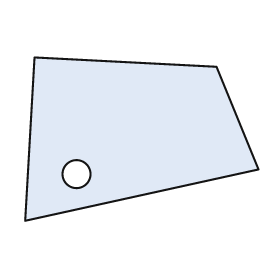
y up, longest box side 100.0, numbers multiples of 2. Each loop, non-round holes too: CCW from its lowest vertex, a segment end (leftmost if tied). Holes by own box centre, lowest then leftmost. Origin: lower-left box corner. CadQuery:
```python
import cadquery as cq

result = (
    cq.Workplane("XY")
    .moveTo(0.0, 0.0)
    .lineTo(100.0, 22.0)
    .lineTo(82.0, 66.0)
    .lineTo(4.0, 70.0)
    .close()
    .moveTo(22.0, 20.0)
    .circle(6.0)
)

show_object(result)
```